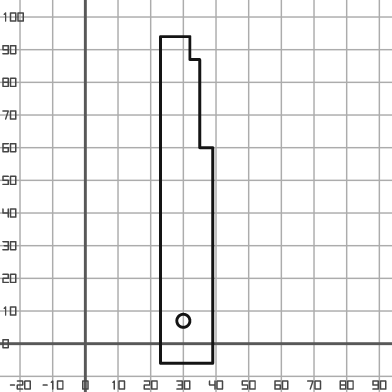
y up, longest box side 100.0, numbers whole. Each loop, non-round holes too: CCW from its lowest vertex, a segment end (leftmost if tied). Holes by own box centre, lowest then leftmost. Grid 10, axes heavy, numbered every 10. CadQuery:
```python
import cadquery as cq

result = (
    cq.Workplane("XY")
    .moveTo(23.0, -6.0)
    .lineTo(39.0, -6.0)
    .lineTo(39.0, 60.0)
    .lineTo(35.0, 60.0)
    .lineTo(35.0, 87.0)
    .lineTo(32.0, 87.0)
    .lineTo(32.0, 94.0)
    .lineTo(23.0, 94.0)
    .close()
    .moveTo(30.0, 7.0)
    .circle(2.0)
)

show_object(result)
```